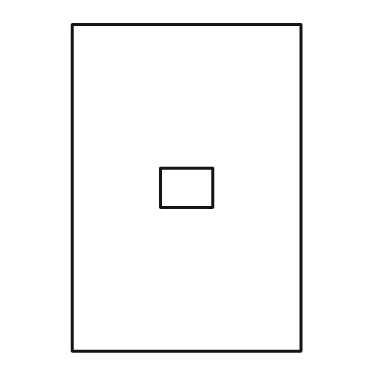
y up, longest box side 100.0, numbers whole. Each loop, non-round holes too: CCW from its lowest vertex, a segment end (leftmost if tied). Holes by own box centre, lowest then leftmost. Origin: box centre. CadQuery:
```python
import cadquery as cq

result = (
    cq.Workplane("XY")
    .moveTo(-35.0, -50.0)
    .lineTo(35.0, -50.0)
    .lineTo(35.0, 50.0)
    .lineTo(-35.0, 50.0)
    .close()
    .moveTo(-8.0, -6.0)
    .lineTo(8.0, -6.0)
    .lineTo(8.0, 6.0)
    .lineTo(-8.0, 6.0)
    .close()
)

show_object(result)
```